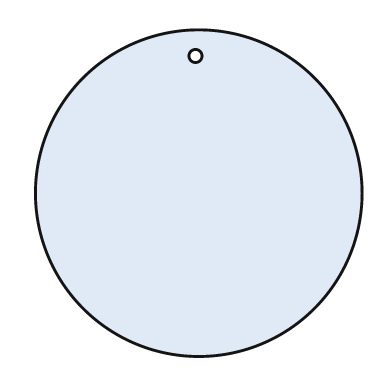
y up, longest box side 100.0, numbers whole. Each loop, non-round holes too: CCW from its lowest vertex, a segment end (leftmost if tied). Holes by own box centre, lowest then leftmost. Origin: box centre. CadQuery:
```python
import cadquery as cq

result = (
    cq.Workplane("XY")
    .moveTo(0.0, 0.0)
    .circle(50.0)
    .moveTo(-1.0, 42.0)
    .circle(2.0)
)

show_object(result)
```